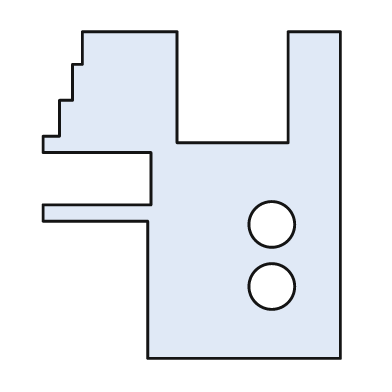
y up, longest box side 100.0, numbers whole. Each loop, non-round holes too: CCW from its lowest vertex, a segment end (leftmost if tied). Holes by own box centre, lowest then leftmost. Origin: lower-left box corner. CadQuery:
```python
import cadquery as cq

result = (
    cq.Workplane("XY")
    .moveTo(32.0, 0.0)
    .lineTo(91.0, 0.0)
    .lineTo(91.0, 100.0)
    .lineTo(75.0, 100.0)
    .lineTo(75.0, 66.0)
    .lineTo(41.0, 66.0)
    .lineTo(41.0, 100.0)
    .lineTo(12.0, 100.0)
    .lineTo(12.0, 90.0)
    .lineTo(9.0, 90.0)
    .lineTo(9.0, 79.0)
    .lineTo(5.0, 79.0)
    .lineTo(5.0, 68.0)
    .lineTo(0.0, 68.0)
    .lineTo(0.0, 63.0)
    .lineTo(33.0, 63.0)
    .lineTo(33.0, 47.0)
    .lineTo(0.0, 47.0)
    .lineTo(0.0, 42.0)
    .lineTo(32.0, 42.0)
    .close()
    .moveTo(70.0, 22.0)
    .circle(7.0)
    .moveTo(70.0, 41.0)
    .circle(7.0)
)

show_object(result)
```